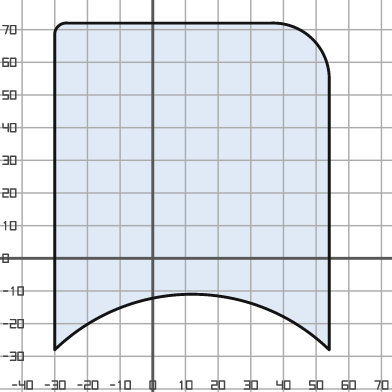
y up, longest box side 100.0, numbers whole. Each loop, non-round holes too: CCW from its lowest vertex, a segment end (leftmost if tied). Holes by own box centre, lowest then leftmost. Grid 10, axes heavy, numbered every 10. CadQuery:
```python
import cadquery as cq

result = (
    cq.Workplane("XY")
    .moveTo(-30.0, -28.0)
    .threePointArc((12.0, -11.0), (54.0, -28.0))
    .lineTo(54.0, 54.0)
    .threePointArc((49.0, 67.0), (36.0, 72.0))
    .lineTo(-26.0, 72.0)
    .threePointArc((-29.0, 71.0), (-30.0, 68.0))
    .close()
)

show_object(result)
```